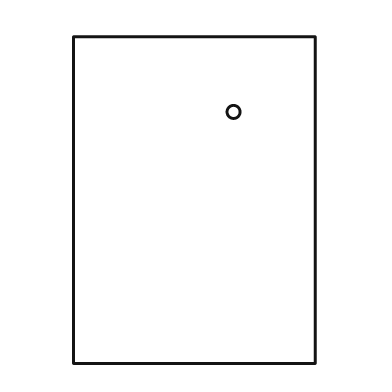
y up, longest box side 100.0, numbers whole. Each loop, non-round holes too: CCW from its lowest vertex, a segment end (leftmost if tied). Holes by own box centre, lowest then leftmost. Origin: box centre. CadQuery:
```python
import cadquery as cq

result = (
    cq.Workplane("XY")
    .moveTo(-37.0, -50.0)
    .lineTo(37.0, -50.0)
    .lineTo(37.0, 50.0)
    .lineTo(-37.0, 50.0)
    .close()
    .moveTo(12.0, 27.0)
    .circle(2.0)
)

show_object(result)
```